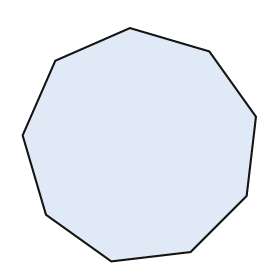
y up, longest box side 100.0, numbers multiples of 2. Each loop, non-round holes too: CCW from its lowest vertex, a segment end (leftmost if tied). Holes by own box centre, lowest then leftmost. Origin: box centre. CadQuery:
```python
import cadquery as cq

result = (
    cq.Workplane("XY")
    .moveTo(-12.0, -50.0)
    .lineTo(22.0, -46.0)
    .lineTo(46.0, -22.0)
    .lineTo(50.0, 12.0)
    .lineTo(30.0, 40.0)
    .lineTo(-4.0, 50.0)
    .lineTo(-36.0, 36.0)
    .lineTo(-50.0, 4.0)
    .lineTo(-40.0, -30.0)
    .close()
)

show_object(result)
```